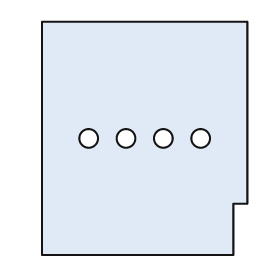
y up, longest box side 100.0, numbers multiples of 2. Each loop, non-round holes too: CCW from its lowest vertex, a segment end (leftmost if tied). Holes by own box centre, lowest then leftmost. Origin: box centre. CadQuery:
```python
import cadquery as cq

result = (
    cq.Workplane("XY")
    .moveTo(-44.0, -50.0)
    .lineTo(38.0, -50.0)
    .lineTo(38.0, -28.0)
    .lineTo(44.0, -28.0)
    .lineTo(44.0, 50.0)
    .lineTo(-44.0, 50.0)
    .close()
    .moveTo(-24.0, 0.0)
    .circle(4.0)
    .moveTo(-8.0, 0.0)
    .circle(4.0)
    .moveTo(8.0, 0.0)
    .circle(4.0)
    .moveTo(24.0, 0.0)
    .circle(4.0)
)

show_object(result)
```